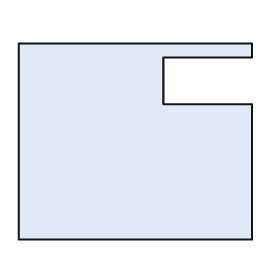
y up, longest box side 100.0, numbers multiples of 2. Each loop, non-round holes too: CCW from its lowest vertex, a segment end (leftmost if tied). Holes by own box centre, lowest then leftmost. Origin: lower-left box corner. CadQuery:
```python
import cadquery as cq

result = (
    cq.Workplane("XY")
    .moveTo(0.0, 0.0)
    .lineTo(100.0, 0.0)
    .lineTo(100.0, 58.0)
    .lineTo(62.0, 58.0)
    .lineTo(62.0, 78.0)
    .lineTo(100.0, 78.0)
    .lineTo(100.0, 84.0)
    .lineTo(0.0, 84.0)
    .close()
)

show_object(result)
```